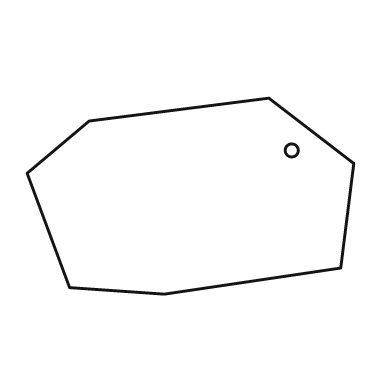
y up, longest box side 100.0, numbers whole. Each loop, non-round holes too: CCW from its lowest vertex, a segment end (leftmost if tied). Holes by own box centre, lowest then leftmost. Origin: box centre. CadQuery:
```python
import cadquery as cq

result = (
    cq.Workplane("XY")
    .moveTo(-8.0, -30.0)
    .lineTo(46.0, -22.0)
    .lineTo(50.0, 10.0)
    .lineTo(24.0, 30.0)
    .lineTo(-31.0, 23.0)
    .lineTo(-50.0, 7.0)
    .lineTo(-37.0, -28.0)
    .close()
    .moveTo(31.0, 14.0)
    .circle(2.0)
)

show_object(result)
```